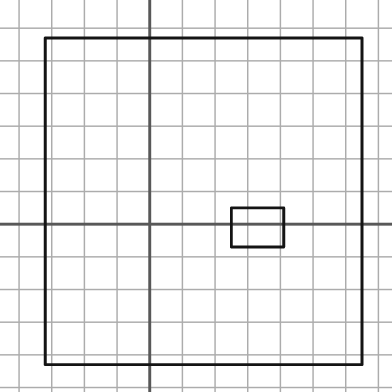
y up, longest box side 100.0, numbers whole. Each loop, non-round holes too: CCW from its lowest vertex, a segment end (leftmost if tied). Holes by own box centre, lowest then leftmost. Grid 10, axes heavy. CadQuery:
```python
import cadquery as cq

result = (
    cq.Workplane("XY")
    .moveTo(-32.0, -43.0)
    .lineTo(65.0, -43.0)
    .lineTo(65.0, 57.0)
    .lineTo(-32.0, 57.0)
    .close()
    .moveTo(25.0, -7.0)
    .lineTo(41.0, -7.0)
    .lineTo(41.0, 5.0)
    .lineTo(25.0, 5.0)
    .close()
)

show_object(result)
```